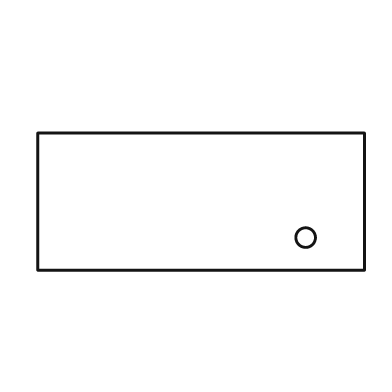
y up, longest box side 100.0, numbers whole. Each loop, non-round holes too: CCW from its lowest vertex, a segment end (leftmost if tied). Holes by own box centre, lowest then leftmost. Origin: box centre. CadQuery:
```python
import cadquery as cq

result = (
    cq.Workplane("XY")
    .moveTo(-50.0, -21.0)
    .lineTo(50.0, -21.0)
    .lineTo(50.0, 21.0)
    .lineTo(-50.0, 21.0)
    .close()
    .moveTo(32.0, -11.0)
    .circle(3.0)
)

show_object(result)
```